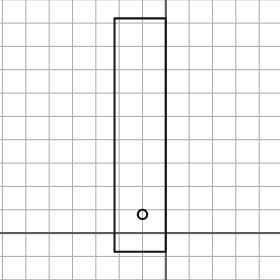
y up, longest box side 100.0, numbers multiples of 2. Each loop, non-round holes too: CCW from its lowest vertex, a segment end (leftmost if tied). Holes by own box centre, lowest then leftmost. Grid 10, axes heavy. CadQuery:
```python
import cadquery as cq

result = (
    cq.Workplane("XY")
    .moveTo(-22.0, -8.0)
    .lineTo(0.0, -8.0)
    .lineTo(0.0, 92.0)
    .lineTo(-22.0, 92.0)
    .close()
    .moveTo(-10.0, 8.0)
    .circle(2.0)
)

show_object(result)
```